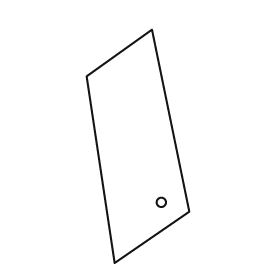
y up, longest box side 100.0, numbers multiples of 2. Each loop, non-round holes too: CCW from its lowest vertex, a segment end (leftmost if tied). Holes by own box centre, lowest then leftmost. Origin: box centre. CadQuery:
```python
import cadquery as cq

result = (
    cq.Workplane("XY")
    .moveTo(-10.0, -50.0)
    .lineTo(22.0, -28.0)
    .lineTo(6.0, 50.0)
    .lineTo(-22.0, 30.0)
    .close()
    .moveTo(10.0, -24.0)
    .circle(2.0)
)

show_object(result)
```